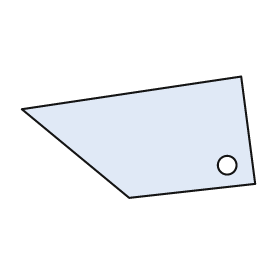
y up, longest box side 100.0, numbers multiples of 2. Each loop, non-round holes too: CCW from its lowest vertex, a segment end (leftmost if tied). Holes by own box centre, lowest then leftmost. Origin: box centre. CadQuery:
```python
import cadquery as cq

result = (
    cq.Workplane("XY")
    .moveTo(-4.0, -26.0)
    .lineTo(50.0, -20.0)
    .lineTo(44.0, 26.0)
    .lineTo(-50.0, 12.0)
    .close()
    .moveTo(38.0, -12.0)
    .circle(4.0)
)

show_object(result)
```